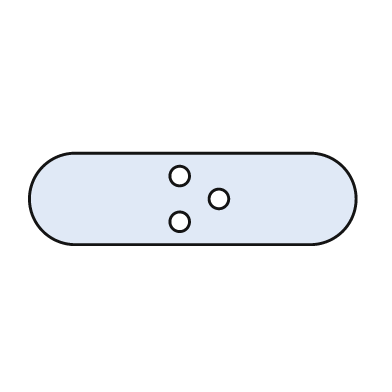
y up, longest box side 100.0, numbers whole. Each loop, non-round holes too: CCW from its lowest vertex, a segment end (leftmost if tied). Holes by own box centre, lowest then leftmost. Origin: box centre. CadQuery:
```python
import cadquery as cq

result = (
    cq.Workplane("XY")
    .moveTo(-36.0, -14.0)
    .lineTo(36.0, -14.0)
    .threePointArc((50.0, 0.0), (36.0, 14.0))
    .lineTo(-36.0, 14.0)
    .threePointArc((-50.0, 0.0), (-36.0, -14.0))
    .close()
    .moveTo(-4.0, -7.0)
    .circle(3.0)
    .moveTo(8.0, 0.0)
    .circle(3.0)
    .moveTo(-4.0, 7.0)
    .circle(3.0)
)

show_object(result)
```